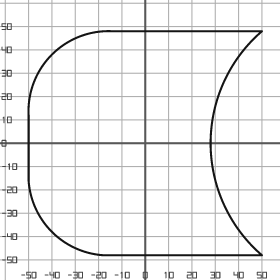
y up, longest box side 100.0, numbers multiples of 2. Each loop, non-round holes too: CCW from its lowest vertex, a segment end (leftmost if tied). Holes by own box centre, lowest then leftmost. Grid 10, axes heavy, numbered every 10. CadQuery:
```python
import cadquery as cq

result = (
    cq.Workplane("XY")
    .moveTo(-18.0, -48.0)
    .lineTo(50.0, -48.0)
    .threePointArc((28.0, 0.0), (50.0, 48.0))
    .lineTo(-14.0, 48.0)
    .threePointArc((-40.0, 38.0), (-50.0, 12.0))
    .lineTo(-50.0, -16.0)
    .threePointArc((-40.0, -38.0), (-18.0, -48.0))
    .close()
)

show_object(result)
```